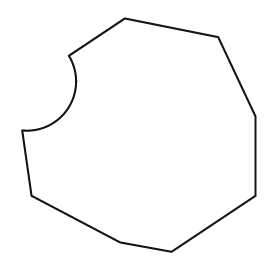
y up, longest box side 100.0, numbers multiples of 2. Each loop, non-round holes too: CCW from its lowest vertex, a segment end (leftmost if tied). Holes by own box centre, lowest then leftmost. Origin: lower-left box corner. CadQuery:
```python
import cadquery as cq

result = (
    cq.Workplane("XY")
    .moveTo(64.0, 0.0)
    .lineTo(100.0, 24.0)
    .lineTo(100.0, 58.0)
    .lineTo(84.0, 92.0)
    .lineTo(44.0, 100.0)
    .lineTo(20.0, 84.0)
    .threePointArc((20.0, 62.0), (0.0, 52.0))
    .lineTo(4.0, 24.0)
    .lineTo(42.0, 4.0)
    .close()
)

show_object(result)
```